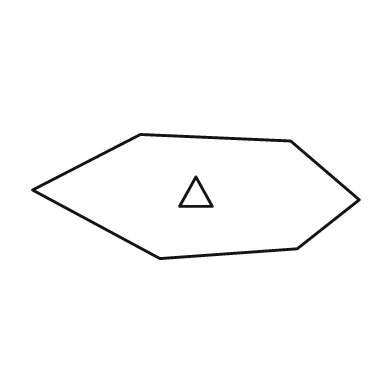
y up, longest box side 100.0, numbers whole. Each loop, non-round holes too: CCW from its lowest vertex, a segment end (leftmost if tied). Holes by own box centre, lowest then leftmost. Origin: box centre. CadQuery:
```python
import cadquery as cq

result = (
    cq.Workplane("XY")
    .moveTo(-11.0, -19.0)
    .lineTo(31.0, -16.0)
    .lineTo(50.0, -1.0)
    .lineTo(29.0, 17.0)
    .lineTo(-17.0, 19.0)
    .lineTo(-50.0, 2.0)
    .close()
    .moveTo(-5.0, -3.0)
    .lineTo(5.0, -3.0)
    .lineTo(0.0, 6.0)
    .close()
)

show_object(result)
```